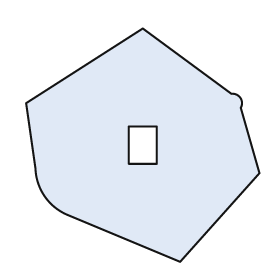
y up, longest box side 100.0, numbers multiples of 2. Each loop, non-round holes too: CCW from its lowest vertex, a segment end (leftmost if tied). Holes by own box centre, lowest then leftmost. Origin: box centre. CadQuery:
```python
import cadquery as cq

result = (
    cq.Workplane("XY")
    .moveTo(16.0, -50.0)
    .lineTo(50.0, -12.0)
    .lineTo(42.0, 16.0)
    .threePointArc((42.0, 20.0), (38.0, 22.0))
    .lineTo(0.0, 50.0)
    .lineTo(-50.0, 18.0)
    .lineTo(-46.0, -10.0)
    .threePointArc((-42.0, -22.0), (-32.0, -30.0))
    .close()
    .moveTo(-6.0, -8.0)
    .lineTo(6.0, -8.0)
    .lineTo(6.0, 8.0)
    .lineTo(-6.0, 8.0)
    .close()
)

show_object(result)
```